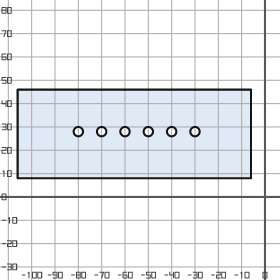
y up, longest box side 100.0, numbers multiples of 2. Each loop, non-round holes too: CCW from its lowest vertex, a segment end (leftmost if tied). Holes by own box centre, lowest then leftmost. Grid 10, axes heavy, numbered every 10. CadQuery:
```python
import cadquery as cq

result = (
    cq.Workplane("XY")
    .moveTo(-106.0, 8.0)
    .lineTo(-6.0, 8.0)
    .lineTo(-6.0, 46.0)
    .lineTo(-106.0, 46.0)
    .close()
    .moveTo(-80.0, 28.0)
    .circle(2.0)
    .moveTo(-70.0, 28.0)
    .circle(2.0)
    .moveTo(-60.0, 28.0)
    .circle(2.0)
    .moveTo(-50.0, 28.0)
    .circle(2.0)
    .moveTo(-40.0, 28.0)
    .circle(2.0)
    .moveTo(-30.0, 28.0)
    .circle(2.0)
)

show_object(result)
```